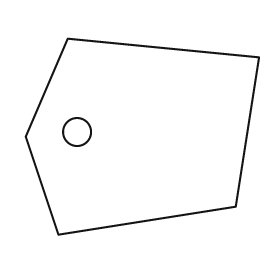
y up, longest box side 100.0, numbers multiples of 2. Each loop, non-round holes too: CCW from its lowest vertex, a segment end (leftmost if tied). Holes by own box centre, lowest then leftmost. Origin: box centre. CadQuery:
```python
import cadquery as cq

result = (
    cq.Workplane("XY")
    .moveTo(-36.0, -42.0)
    .lineTo(40.0, -30.0)
    .lineTo(50.0, 34.0)
    .lineTo(-32.0, 42.0)
    .lineTo(-50.0, 0.0)
    .close()
    .moveTo(-28.0, 2.0)
    .circle(6.0)
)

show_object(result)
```